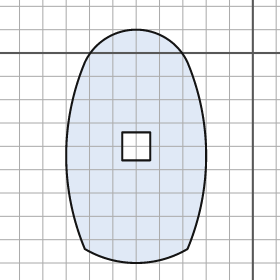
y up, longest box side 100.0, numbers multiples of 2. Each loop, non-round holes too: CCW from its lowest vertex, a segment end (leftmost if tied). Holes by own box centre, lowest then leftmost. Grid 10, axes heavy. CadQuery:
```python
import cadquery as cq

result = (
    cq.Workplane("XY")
    .moveTo(-72.0, -84.0)
    .threePointArc((-50.0, -90.0), (-28.0, -84.0))
    .threePointArc((-20.0, -44.0), (-28.0, -4.0))
    .threePointArc((-50.0, 10.0), (-72.0, -4.0))
    .threePointArc((-80.0, -44.0), (-72.0, -84.0))
    .close()
    .moveTo(-56.0, -46.0)
    .lineTo(-44.0, -46.0)
    .lineTo(-44.0, -34.0)
    .lineTo(-56.0, -34.0)
    .close()
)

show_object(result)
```